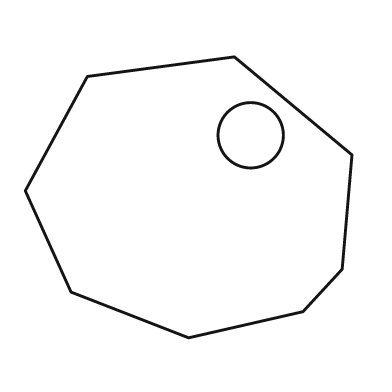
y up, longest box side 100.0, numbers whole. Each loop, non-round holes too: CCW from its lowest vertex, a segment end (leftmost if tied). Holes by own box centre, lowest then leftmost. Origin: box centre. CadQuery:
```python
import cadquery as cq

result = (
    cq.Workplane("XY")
    .moveTo(0.0, -43.0)
    .lineTo(35.0, -35.0)
    .lineTo(47.0, -22.0)
    .lineTo(50.0, 13.0)
    .lineTo(14.0, 43.0)
    .lineTo(-31.0, 37.0)
    .lineTo(-50.0, 2.0)
    .lineTo(-36.0, -29.0)
    .close()
    .moveTo(19.0, 19.0)
    .circle(10.0)
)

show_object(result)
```